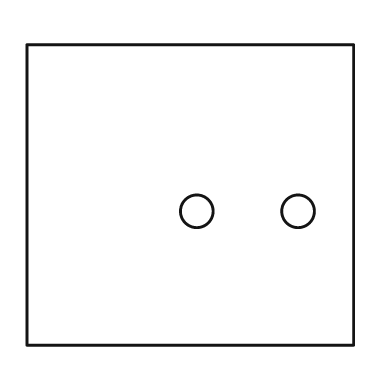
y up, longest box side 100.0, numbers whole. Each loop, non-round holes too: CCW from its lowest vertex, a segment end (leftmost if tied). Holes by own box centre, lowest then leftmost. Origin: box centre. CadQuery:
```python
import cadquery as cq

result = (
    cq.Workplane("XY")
    .moveTo(-50.0, -46.0)
    .lineTo(50.0, -46.0)
    .lineTo(50.0, 46.0)
    .lineTo(-50.0, 46.0)
    .close()
    .moveTo(2.0, -5.0)
    .circle(5.0)
    .moveTo(33.0, -5.0)
    .circle(5.0)
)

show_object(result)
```